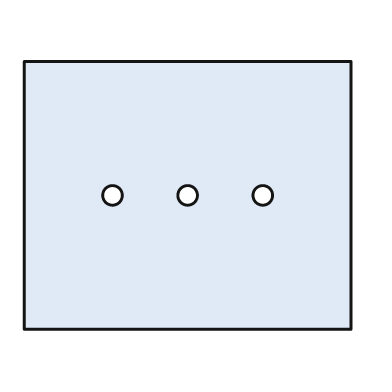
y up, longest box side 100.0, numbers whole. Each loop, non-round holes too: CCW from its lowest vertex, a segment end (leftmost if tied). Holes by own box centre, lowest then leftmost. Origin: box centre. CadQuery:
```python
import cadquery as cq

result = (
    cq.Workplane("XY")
    .moveTo(-50.0, -41.0)
    .lineTo(50.0, -41.0)
    .lineTo(50.0, 41.0)
    .lineTo(-50.0, 41.0)
    .close()
    .moveTo(-23.0, 0.0)
    .circle(3.0)
    .moveTo(0.0, 0.0)
    .circle(3.0)
    .moveTo(23.0, 0.0)
    .circle(3.0)
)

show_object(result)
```